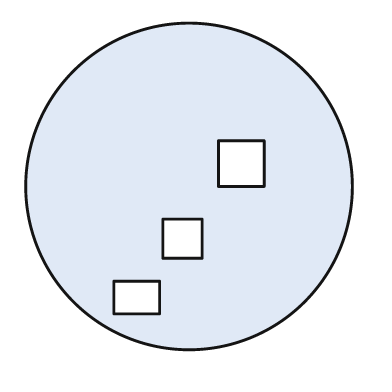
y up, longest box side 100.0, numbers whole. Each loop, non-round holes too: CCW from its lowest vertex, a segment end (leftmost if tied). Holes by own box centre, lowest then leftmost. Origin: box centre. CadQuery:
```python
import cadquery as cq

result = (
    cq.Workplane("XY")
    .moveTo(0.0, 0.0)
    .circle(50.0)
    .moveTo(-23.0, -39.0)
    .lineTo(-9.0, -39.0)
    .lineTo(-9.0, -29.0)
    .lineTo(-23.0, -29.0)
    .close()
    .moveTo(-8.0, -22.0)
    .lineTo(4.0, -22.0)
    .lineTo(4.0, -10.0)
    .lineTo(-8.0, -10.0)
    .close()
    .moveTo(9.0, 0.0)
    .lineTo(23.0, 0.0)
    .lineTo(23.0, 14.0)
    .lineTo(9.0, 14.0)
    .close()
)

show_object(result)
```